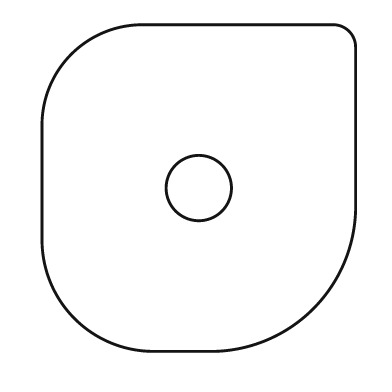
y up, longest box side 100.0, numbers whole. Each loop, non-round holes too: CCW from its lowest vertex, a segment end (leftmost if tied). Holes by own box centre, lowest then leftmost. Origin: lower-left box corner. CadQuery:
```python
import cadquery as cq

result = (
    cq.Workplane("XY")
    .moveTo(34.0, 0.0)
    .lineTo(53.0, 0.0)
    .threePointArc((83.0, 13.0), (96.0, 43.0))
    .lineTo(96.0, 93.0)
    .threePointArc((94.0, 98.0), (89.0, 100.0))
    .lineTo(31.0, 100.0)
    .threePointArc((9.0, 91.0), (0.0, 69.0))
    .lineTo(0.0, 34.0)
    .threePointArc((10.0, 10.0), (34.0, 0.0))
    .close()
    .moveTo(48.0, 50.0)
    .circle(10.0)
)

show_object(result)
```